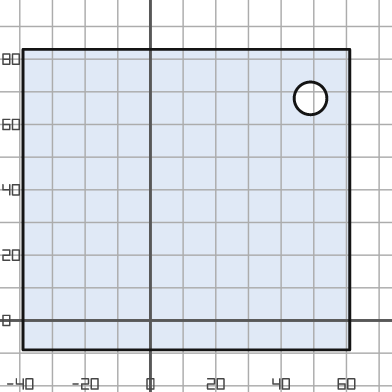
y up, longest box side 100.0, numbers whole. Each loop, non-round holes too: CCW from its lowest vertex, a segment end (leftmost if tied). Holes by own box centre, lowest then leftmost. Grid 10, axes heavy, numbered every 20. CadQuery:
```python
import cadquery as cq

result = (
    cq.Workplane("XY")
    .moveTo(-39.0, -9.0)
    .lineTo(61.0, -9.0)
    .lineTo(61.0, 83.0)
    .lineTo(-39.0, 83.0)
    .close()
    .moveTo(49.0, 68.0)
    .circle(5.0)
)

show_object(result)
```